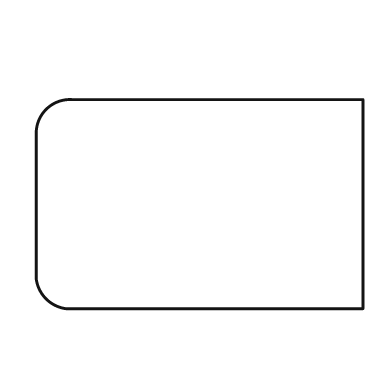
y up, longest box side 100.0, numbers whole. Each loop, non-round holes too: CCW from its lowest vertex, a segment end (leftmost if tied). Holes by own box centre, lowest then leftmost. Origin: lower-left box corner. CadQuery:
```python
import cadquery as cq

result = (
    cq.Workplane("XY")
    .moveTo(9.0, 0.0)
    .lineTo(100.0, 0.0)
    .lineTo(100.0, 64.0)
    .lineTo(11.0, 64.0)
    .threePointArc((3.0, 61.0), (0.0, 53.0))
    .lineTo(0.0, 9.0)
    .threePointArc((3.0, 3.0), (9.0, 0.0))
    .close()
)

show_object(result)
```